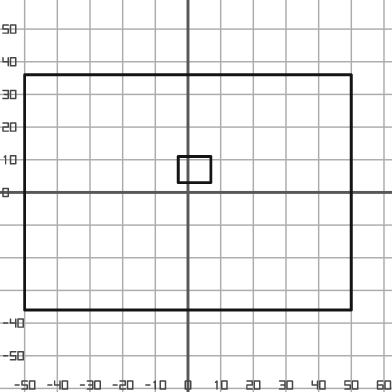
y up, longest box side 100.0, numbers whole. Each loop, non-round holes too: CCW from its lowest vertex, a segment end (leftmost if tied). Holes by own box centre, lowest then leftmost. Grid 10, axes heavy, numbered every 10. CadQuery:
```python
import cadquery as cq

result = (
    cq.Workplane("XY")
    .moveTo(-50.0, -36.0)
    .lineTo(50.0, -36.0)
    .lineTo(50.0, 36.0)
    .lineTo(-50.0, 36.0)
    .close()
    .moveTo(-3.0, 3.0)
    .lineTo(7.0, 3.0)
    .lineTo(7.0, 11.0)
    .lineTo(-3.0, 11.0)
    .close()
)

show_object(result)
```